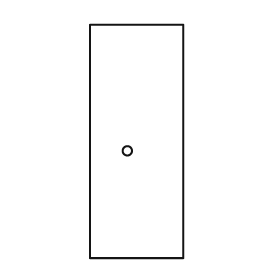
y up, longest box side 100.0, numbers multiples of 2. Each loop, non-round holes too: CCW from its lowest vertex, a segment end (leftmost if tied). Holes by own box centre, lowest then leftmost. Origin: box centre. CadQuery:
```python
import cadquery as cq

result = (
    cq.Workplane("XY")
    .moveTo(-20.0, -50.0)
    .lineTo(20.0, -50.0)
    .lineTo(20.0, 50.0)
    .lineTo(-20.0, 50.0)
    .close()
    .moveTo(-4.0, -4.0)
    .circle(2.0)
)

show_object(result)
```